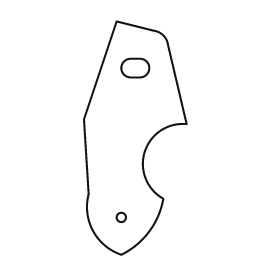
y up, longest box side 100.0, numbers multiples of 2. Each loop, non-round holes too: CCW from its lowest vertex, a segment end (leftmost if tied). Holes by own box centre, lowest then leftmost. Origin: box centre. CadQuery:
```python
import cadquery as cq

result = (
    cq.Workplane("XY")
    .moveTo(-6.0, -50.0)
    .threePointArc((6.0, -40.0), (12.0, -26.0))
    .threePointArc((4.0, -6.0), (22.0, 6.0))
    .lineTo(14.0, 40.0)
    .threePointArc((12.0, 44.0), (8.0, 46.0))
    .lineTo(-8.0, 50.0)
    .lineTo(-22.0, 8.0)
    .lineTo(-20.0, -24.0)
    .threePointArc((-18.0, -40.0), (-6.0, -50.0))
    .close()
    .moveTo(-6.0, -34.0)
    .circle(2.0)
    .moveTo(-2.0, 26.0)
    .lineTo(2.0, 26.0)
    .threePointArc((6.0, 30.0), (2.0, 34.0))
    .lineTo(-2.0, 34.0)
    .threePointArc((-6.0, 30.0), (-2.0, 26.0))
    .close()
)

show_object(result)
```